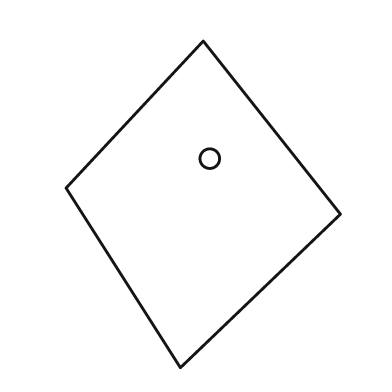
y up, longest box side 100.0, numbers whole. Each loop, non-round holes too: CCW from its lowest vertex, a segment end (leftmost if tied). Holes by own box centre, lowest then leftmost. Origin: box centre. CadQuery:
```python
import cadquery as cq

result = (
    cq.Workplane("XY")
    .moveTo(-7.0, -50.0)
    .lineTo(42.0, -3.0)
    .lineTo(0.0, 50.0)
    .lineTo(-42.0, 5.0)
    .close()
    .moveTo(2.0, 14.0)
    .circle(3.0)
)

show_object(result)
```